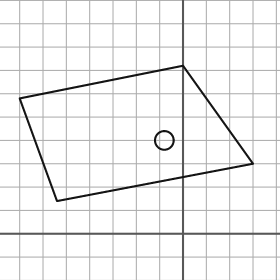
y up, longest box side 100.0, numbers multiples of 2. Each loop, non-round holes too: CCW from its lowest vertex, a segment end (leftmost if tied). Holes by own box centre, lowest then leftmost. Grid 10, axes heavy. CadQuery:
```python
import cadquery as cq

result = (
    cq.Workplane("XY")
    .moveTo(-54.0, 14.0)
    .lineTo(30.0, 30.0)
    .lineTo(0.0, 72.0)
    .lineTo(-70.0, 58.0)
    .close()
    .moveTo(-8.0, 40.0)
    .circle(4.0)
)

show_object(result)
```